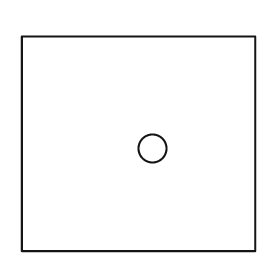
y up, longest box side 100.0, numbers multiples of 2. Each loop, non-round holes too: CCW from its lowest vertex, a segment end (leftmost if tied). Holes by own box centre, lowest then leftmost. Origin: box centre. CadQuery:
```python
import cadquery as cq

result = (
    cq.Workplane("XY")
    .moveTo(-50.0, -46.0)
    .lineTo(50.0, -46.0)
    .lineTo(50.0, 46.0)
    .lineTo(-50.0, 46.0)
    .close()
    .moveTo(6.0, -2.0)
    .circle(6.0)
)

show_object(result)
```